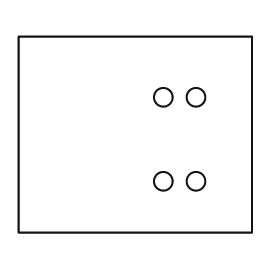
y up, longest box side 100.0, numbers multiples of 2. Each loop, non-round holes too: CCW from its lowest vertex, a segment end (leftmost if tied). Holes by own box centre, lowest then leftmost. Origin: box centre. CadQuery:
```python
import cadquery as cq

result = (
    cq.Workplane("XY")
    .moveTo(-50.0, -42.0)
    .lineTo(50.0, -42.0)
    .lineTo(50.0, 42.0)
    .lineTo(-50.0, 42.0)
    .close()
    .moveTo(12.0, -20.0)
    .circle(4.0)
    .moveTo(26.0, -20.0)
    .circle(4.0)
    .moveTo(12.0, 16.0)
    .circle(4.0)
    .moveTo(26.0, 16.0)
    .circle(4.0)
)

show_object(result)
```